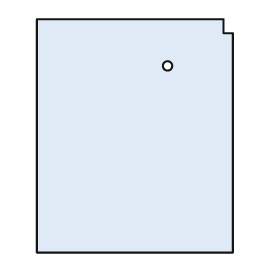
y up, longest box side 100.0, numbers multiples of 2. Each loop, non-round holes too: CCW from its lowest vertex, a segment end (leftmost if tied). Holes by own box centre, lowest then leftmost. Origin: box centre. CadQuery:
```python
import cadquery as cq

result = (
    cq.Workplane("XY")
    .moveTo(-42.0, -50.0)
    .lineTo(42.0, -50.0)
    .lineTo(42.0, 44.0)
    .lineTo(38.0, 44.0)
    .lineTo(38.0, 50.0)
    .lineTo(-42.0, 50.0)
    .close()
    .moveTo(14.0, 30.0)
    .circle(2.0)
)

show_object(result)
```